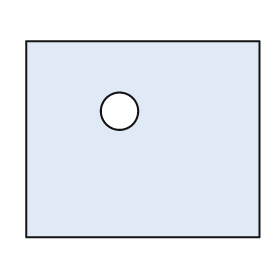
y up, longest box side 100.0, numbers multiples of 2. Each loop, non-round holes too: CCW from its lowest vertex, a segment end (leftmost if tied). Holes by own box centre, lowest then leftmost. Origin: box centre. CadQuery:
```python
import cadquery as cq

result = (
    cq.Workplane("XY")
    .moveTo(-50.0, -42.0)
    .lineTo(50.0, -42.0)
    .lineTo(50.0, 42.0)
    .lineTo(-50.0, 42.0)
    .close()
    .moveTo(-10.0, 12.0)
    .circle(8.0)
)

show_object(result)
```